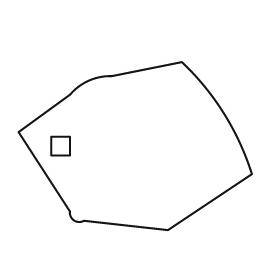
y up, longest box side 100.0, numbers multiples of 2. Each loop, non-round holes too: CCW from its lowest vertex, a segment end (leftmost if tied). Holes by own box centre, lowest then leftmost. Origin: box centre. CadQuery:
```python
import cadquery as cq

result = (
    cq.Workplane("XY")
    .moveTo(14.0, -36.0)
    .lineTo(50.0, -12.0)
    .threePointArc((38.0, 14.0), (20.0, 36.0))
    .lineTo(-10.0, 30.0)
    .threePointArc((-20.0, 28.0), (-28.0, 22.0))
    .lineTo(-50.0, 6.0)
    .lineTo(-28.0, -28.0)
    .threePointArc((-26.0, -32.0), (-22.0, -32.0))
    .close()
    .moveTo(-36.0, -4.0)
    .lineTo(-28.0, -4.0)
    .lineTo(-28.0, 4.0)
    .lineTo(-36.0, 4.0)
    .close()
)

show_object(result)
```